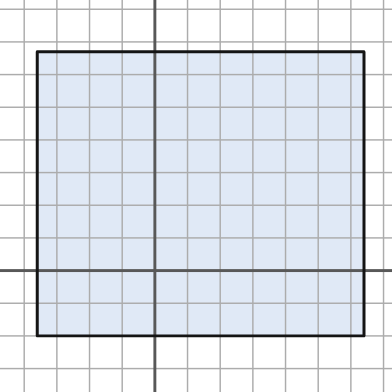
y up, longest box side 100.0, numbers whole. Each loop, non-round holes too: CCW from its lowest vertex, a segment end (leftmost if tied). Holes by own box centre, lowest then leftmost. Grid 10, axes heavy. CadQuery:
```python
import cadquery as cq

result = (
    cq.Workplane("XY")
    .moveTo(-36.0, -20.0)
    .lineTo(64.0, -20.0)
    .lineTo(64.0, 67.0)
    .lineTo(-36.0, 67.0)
    .close()
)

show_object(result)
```